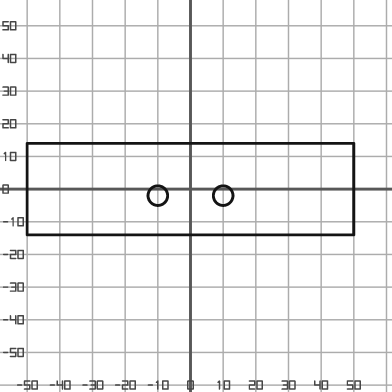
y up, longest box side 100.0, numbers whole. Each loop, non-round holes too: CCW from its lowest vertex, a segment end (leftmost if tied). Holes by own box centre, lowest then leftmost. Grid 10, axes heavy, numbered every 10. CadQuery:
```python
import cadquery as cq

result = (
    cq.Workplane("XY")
    .moveTo(-50.0, -14.0)
    .lineTo(50.0, -14.0)
    .lineTo(50.0, 14.0)
    .lineTo(-50.0, 14.0)
    .close()
    .moveTo(-10.0, -2.0)
    .circle(3.0)
    .moveTo(10.0, -2.0)
    .circle(3.0)
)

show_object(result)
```